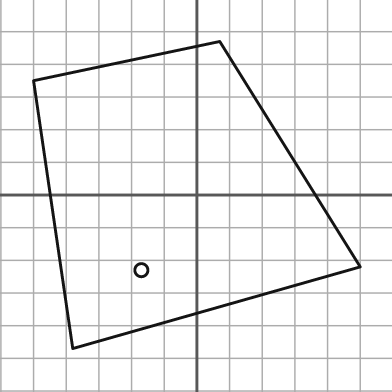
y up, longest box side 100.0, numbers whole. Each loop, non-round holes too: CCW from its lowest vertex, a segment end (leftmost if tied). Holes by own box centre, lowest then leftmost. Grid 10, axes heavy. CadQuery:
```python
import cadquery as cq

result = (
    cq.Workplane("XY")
    .moveTo(-38.0, -47.0)
    .lineTo(50.0, -22.0)
    .lineTo(7.0, 47.0)
    .lineTo(-50.0, 35.0)
    .close()
    .moveTo(-17.0, -23.0)
    .circle(2.0)
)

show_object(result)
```